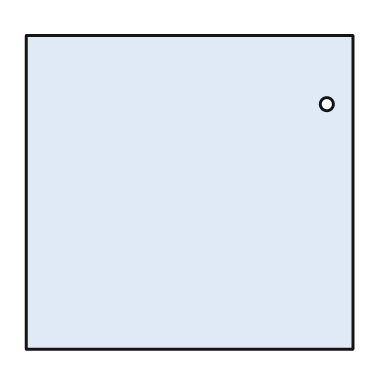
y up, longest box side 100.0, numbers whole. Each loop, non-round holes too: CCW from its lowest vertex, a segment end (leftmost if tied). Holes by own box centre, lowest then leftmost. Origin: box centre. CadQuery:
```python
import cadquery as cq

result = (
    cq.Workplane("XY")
    .moveTo(-50.0, -48.0)
    .lineTo(50.0, -48.0)
    .lineTo(50.0, 48.0)
    .lineTo(-50.0, 48.0)
    .close()
    .moveTo(42.0, 27.0)
    .circle(2.0)
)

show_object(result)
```